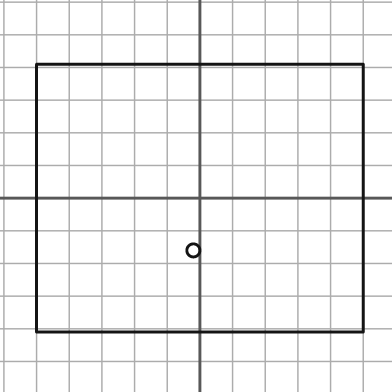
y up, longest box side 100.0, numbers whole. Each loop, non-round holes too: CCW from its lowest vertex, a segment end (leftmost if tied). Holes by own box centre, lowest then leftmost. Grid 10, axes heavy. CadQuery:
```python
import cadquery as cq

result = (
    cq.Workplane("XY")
    .moveTo(-50.0, -41.0)
    .lineTo(50.0, -41.0)
    .lineTo(50.0, 41.0)
    .lineTo(-50.0, 41.0)
    .close()
    .moveTo(-2.0, -16.0)
    .circle(2.0)
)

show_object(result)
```